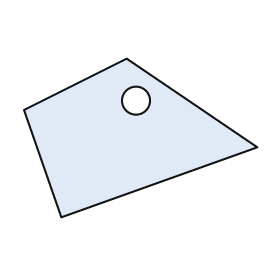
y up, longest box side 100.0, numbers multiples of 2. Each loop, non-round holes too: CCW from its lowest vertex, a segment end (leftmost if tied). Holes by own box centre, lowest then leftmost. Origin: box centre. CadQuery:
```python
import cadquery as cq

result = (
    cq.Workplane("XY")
    .moveTo(-34.0, -34.0)
    .lineTo(50.0, -4.0)
    .lineTo(-6.0, 34.0)
    .lineTo(-50.0, 12.0)
    .close()
    .moveTo(-2.0, 16.0)
    .circle(6.0)
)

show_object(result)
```